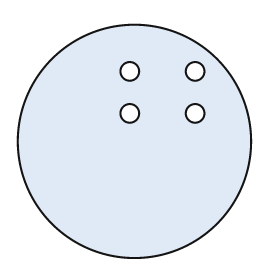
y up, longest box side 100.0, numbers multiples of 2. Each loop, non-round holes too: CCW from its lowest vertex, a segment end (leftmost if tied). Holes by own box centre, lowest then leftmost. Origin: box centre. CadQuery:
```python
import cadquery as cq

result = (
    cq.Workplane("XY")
    .moveTo(0.0, 0.0)
    .circle(50.0)
    .moveTo(-2.0, 12.0)
    .circle(4.0)
    .moveTo(26.0, 12.0)
    .circle(4.0)
    .moveTo(-2.0, 30.0)
    .circle(4.0)
    .moveTo(26.0, 30.0)
    .circle(4.0)
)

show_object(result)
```